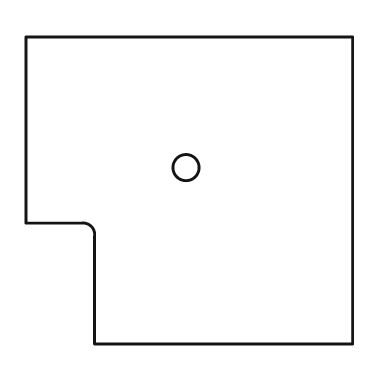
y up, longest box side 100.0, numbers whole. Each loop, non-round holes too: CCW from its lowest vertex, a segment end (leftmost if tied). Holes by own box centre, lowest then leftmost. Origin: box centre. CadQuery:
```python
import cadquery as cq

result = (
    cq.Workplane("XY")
    .moveTo(-29.0, -47.0)
    .lineTo(50.0, -47.0)
    .lineTo(50.0, 47.0)
    .lineTo(-50.0, 47.0)
    .lineTo(-50.0, -10.0)
    .lineTo(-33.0, -10.0)
    .threePointArc((-30.0, -11.0), (-29.0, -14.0))
    .close()
    .moveTo(-1.0, 7.0)
    .circle(4.0)
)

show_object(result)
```